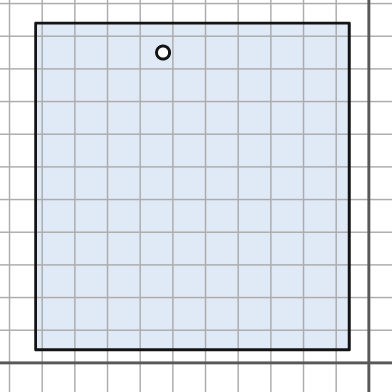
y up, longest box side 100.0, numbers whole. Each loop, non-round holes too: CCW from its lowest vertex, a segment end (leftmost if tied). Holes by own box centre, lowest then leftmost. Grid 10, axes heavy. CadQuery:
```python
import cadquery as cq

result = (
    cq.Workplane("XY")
    .moveTo(-102.0, 4.0)
    .lineTo(-6.0, 4.0)
    .lineTo(-6.0, 104.0)
    .lineTo(-102.0, 104.0)
    .close()
    .moveTo(-63.0, 95.0)
    .circle(2.0)
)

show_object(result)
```